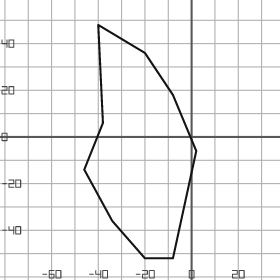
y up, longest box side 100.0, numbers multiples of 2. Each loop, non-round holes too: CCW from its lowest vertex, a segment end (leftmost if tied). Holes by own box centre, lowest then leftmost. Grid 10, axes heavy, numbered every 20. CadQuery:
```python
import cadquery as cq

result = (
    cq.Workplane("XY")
    .moveTo(-20.0, -52.0)
    .lineTo(-8.0, -52.0)
    .lineTo(2.0, -6.0)
    .lineTo(-8.0, 18.0)
    .lineTo(-20.0, 36.0)
    .lineTo(-40.0, 48.0)
    .lineTo(-38.0, 6.0)
    .lineTo(-46.0, -14.0)
    .lineTo(-34.0, -36.0)
    .close()
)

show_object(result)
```